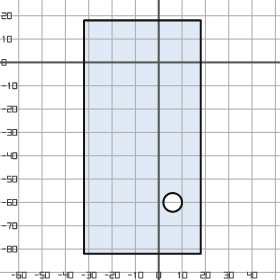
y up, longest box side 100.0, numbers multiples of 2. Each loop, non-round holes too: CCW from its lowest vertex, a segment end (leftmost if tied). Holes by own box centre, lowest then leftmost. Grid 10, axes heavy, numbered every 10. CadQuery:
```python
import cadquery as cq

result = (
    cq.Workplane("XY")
    .moveTo(-32.0, -82.0)
    .lineTo(18.0, -82.0)
    .lineTo(18.0, 18.0)
    .lineTo(-32.0, 18.0)
    .close()
    .moveTo(6.0, -60.0)
    .circle(4.0)
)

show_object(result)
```